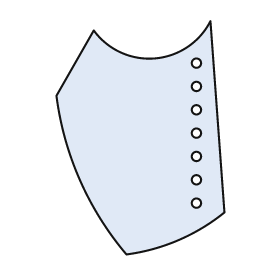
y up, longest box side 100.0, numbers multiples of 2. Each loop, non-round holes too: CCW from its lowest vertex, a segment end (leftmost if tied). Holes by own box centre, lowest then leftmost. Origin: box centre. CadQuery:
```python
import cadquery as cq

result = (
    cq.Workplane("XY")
    .moveTo(-6.0, -50.0)
    .threePointArc((16.0, -44.0), (36.0, -32.0))
    .lineTo(30.0, 50.0)
    .threePointArc((6.0, 34.0), (-20.0, 46.0))
    .lineTo(-36.0, 18.0)
    .threePointArc((-26.0, -18.0), (-6.0, -50.0))
    .close()
    .moveTo(24.0, -28.0)
    .circle(2.0)
    .moveTo(24.0, -18.0)
    .circle(2.0)
    .moveTo(24.0, -8.0)
    .circle(2.0)
    .moveTo(24.0, 2.0)
    .circle(2.0)
    .moveTo(24.0, 12.0)
    .circle(2.0)
    .moveTo(24.0, 22.0)
    .circle(2.0)
    .moveTo(24.0, 32.0)
    .circle(2.0)
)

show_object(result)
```